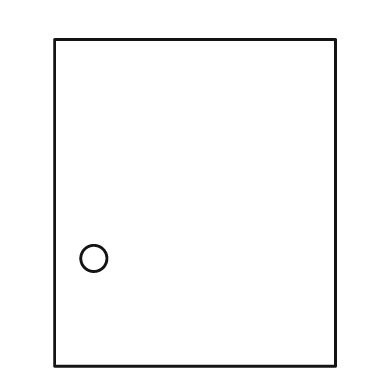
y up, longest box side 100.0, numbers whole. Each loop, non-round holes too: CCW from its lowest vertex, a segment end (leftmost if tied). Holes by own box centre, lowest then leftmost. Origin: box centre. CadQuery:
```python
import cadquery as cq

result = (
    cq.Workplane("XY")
    .moveTo(-43.0, -50.0)
    .lineTo(43.0, -50.0)
    .lineTo(43.0, 50.0)
    .lineTo(-43.0, 50.0)
    .close()
    .moveTo(-31.0, -17.0)
    .circle(4.0)
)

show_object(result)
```